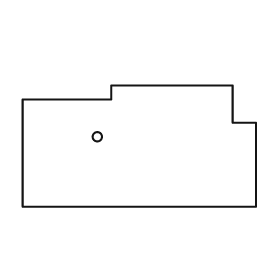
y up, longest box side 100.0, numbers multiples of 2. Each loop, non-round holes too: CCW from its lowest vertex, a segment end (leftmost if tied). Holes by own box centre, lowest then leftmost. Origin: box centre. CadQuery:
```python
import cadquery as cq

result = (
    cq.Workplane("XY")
    .moveTo(-50.0, -26.0)
    .lineTo(50.0, -26.0)
    .lineTo(50.0, 10.0)
    .lineTo(40.0, 10.0)
    .lineTo(40.0, 26.0)
    .lineTo(-12.0, 26.0)
    .lineTo(-12.0, 20.0)
    .lineTo(-50.0, 20.0)
    .close()
    .moveTo(-18.0, 4.0)
    .circle(2.0)
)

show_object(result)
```